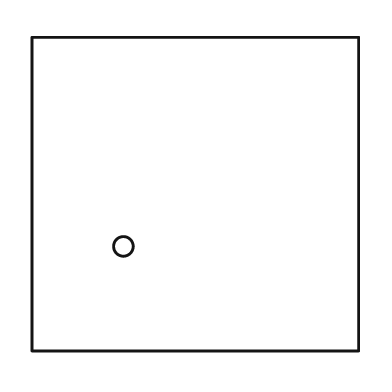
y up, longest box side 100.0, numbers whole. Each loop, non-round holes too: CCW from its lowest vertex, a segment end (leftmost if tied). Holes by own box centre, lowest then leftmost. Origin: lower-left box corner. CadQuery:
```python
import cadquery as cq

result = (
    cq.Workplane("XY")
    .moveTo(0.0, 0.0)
    .lineTo(100.0, 0.0)
    .lineTo(100.0, 96.0)
    .lineTo(0.0, 96.0)
    .close()
    .moveTo(28.0, 32.0)
    .circle(3.0)
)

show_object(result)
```